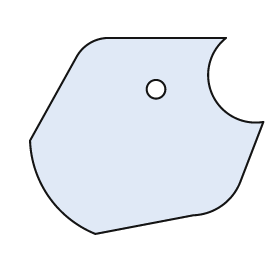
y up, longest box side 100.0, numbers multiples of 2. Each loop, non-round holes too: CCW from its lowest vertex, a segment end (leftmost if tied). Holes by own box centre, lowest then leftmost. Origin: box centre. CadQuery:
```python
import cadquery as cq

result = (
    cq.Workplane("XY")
    .moveTo(-22.0, -42.0)
    .lineTo(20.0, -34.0)
    .threePointArc((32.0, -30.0), (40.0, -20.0))
    .lineTo(50.0, 6.0)
    .threePointArc((28.0, 18.0), (34.0, 42.0))
    .lineTo(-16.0, 42.0)
    .threePointArc((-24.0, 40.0), (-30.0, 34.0))
    .lineTo(-50.0, -2.0)
    .threePointArc((-42.0, -26.0), (-22.0, -42.0))
    .close()
    .moveTo(4.0, 20.0)
    .circle(4.0)
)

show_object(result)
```